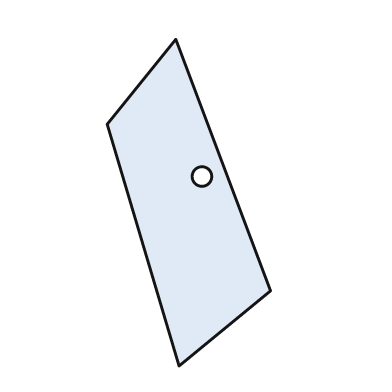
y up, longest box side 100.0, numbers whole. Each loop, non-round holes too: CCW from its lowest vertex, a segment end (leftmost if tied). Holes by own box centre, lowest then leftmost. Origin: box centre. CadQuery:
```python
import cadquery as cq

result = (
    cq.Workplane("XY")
    .moveTo(-3.0, -50.0)
    .lineTo(25.0, -27.0)
    .lineTo(-4.0, 50.0)
    .lineTo(-25.0, 24.0)
    .close()
    .moveTo(4.0, 8.0)
    .circle(3.0)
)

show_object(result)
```